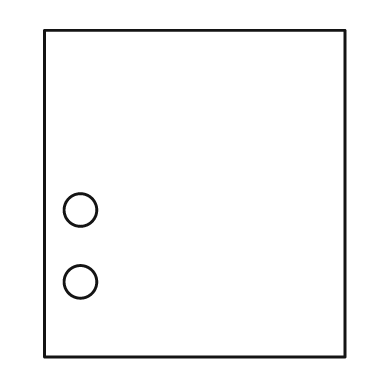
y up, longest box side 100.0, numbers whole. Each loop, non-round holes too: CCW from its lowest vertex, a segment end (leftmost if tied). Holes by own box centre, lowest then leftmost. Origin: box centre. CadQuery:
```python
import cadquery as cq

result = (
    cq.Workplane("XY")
    .moveTo(-46.0, -50.0)
    .lineTo(46.0, -50.0)
    .lineTo(46.0, 50.0)
    .lineTo(-46.0, 50.0)
    .close()
    .moveTo(-35.0, -27.0)
    .circle(5.0)
    .moveTo(-35.0, -5.0)
    .circle(5.0)
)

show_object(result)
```